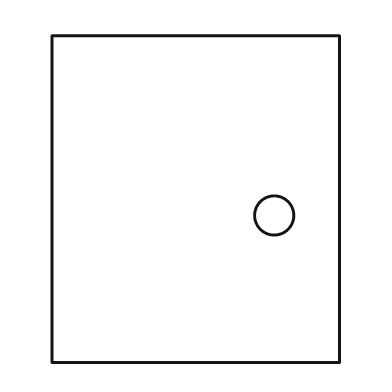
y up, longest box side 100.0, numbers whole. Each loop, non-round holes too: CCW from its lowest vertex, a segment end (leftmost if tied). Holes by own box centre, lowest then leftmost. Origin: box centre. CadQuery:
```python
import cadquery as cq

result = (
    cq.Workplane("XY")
    .moveTo(-44.0, -50.0)
    .lineTo(44.0, -50.0)
    .lineTo(44.0, 50.0)
    .lineTo(-44.0, 50.0)
    .close()
    .moveTo(24.0, -5.0)
    .circle(6.0)
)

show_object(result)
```